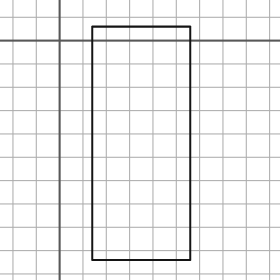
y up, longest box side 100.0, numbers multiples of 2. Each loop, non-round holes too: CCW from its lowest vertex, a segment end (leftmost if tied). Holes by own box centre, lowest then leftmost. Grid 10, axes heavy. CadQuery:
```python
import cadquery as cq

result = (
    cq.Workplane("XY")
    .moveTo(14.0, -94.0)
    .lineTo(56.0, -94.0)
    .lineTo(56.0, 6.0)
    .lineTo(14.0, 6.0)
    .close()
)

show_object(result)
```